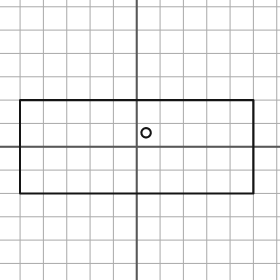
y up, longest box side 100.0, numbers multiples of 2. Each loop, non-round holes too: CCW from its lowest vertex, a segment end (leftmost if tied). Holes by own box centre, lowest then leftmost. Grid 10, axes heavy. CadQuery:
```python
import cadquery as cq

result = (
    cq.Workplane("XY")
    .moveTo(-50.0, -20.0)
    .lineTo(50.0, -20.0)
    .lineTo(50.0, 20.0)
    .lineTo(-50.0, 20.0)
    .close()
    .moveTo(4.0, 6.0)
    .circle(2.0)
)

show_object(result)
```